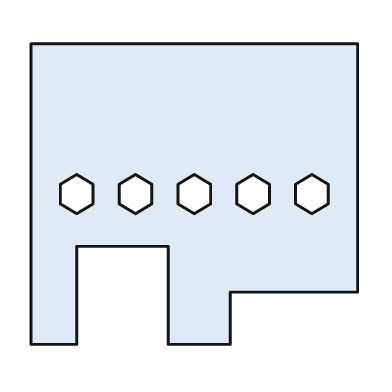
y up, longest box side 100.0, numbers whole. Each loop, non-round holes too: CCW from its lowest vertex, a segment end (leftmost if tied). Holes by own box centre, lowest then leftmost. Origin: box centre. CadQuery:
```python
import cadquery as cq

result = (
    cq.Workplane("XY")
    .moveTo(-50.0, -46.0)
    .lineTo(-36.0, -46.0)
    .lineTo(-36.0, -16.0)
    .lineTo(-8.0, -16.0)
    .lineTo(-8.0, -46.0)
    .lineTo(11.0, -46.0)
    .lineTo(11.0, -30.0)
    .lineTo(50.0, -30.0)
    .lineTo(50.0, 46.0)
    .lineTo(-50.0, 46.0)
    .close()
    .moveTo(-36.0, -6.0)
    .lineTo(-31.0, -3.0)
    .lineTo(-31.0, 3.0)
    .lineTo(-36.0, 6.0)
    .lineTo(-41.0, 3.0)
    .lineTo(-41.0, -3.0)
    .close()
    .moveTo(-18.0, -6.0)
    .lineTo(-13.0, -3.0)
    .lineTo(-13.0, 3.0)
    .lineTo(-18.0, 6.0)
    .lineTo(-23.0, 3.0)
    .lineTo(-23.0, -3.0)
    .close()
    .moveTo(0.0, -6.0)
    .lineTo(5.0, -3.0)
    .lineTo(5.0, 3.0)
    .lineTo(0.0, 6.0)
    .lineTo(-5.0, 3.0)
    .lineTo(-5.0, -3.0)
    .close()
    .moveTo(18.0, -6.0)
    .lineTo(23.0, -3.0)
    .lineTo(23.0, 3.0)
    .lineTo(18.0, 6.0)
    .lineTo(13.0, 3.0)
    .lineTo(13.0, -3.0)
    .close()
    .moveTo(36.0, -6.0)
    .lineTo(41.0, -3.0)
    .lineTo(41.0, 3.0)
    .lineTo(36.0, 6.0)
    .lineTo(31.0, 3.0)
    .lineTo(31.0, -3.0)
    .close()
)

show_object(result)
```